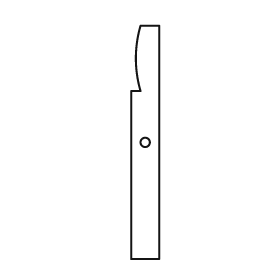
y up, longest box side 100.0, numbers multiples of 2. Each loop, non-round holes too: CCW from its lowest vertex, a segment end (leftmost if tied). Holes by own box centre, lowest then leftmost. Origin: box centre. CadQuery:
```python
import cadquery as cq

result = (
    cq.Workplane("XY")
    .moveTo(-6.0, -50.0)
    .lineTo(6.0, -50.0)
    .lineTo(6.0, 50.0)
    .lineTo(-2.0, 50.0)
    .threePointArc((-4.0, 36.0), (-2.0, 22.0))
    .lineTo(-6.0, 22.0)
    .close()
    .moveTo(0.0, 0.0)
    .circle(2.0)
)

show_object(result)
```